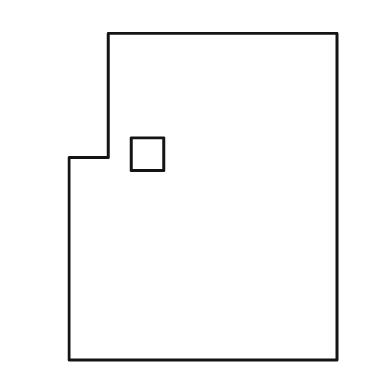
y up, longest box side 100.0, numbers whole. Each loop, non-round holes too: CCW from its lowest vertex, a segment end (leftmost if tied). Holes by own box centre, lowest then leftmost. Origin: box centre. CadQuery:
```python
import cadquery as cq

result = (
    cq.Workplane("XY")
    .moveTo(-41.0, -50.0)
    .lineTo(41.0, -50.0)
    .lineTo(41.0, 50.0)
    .lineTo(-29.0, 50.0)
    .lineTo(-29.0, 12.0)
    .lineTo(-41.0, 12.0)
    .close()
    .moveTo(-22.0, 8.0)
    .lineTo(-12.0, 8.0)
    .lineTo(-12.0, 18.0)
    .lineTo(-22.0, 18.0)
    .close()
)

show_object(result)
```